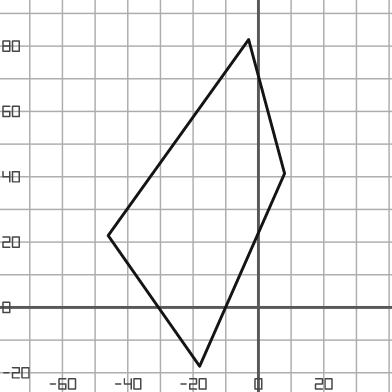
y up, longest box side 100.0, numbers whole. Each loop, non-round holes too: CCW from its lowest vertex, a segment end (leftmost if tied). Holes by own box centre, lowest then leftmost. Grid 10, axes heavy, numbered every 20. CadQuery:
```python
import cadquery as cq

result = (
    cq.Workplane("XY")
    .moveTo(-18.0, -18.0)
    .lineTo(8.0, 41.0)
    .lineTo(-3.0, 82.0)
    .lineTo(-46.0, 22.0)
    .close()
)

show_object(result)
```